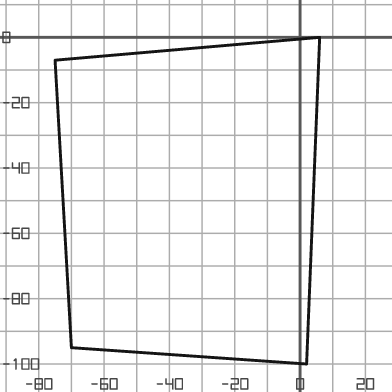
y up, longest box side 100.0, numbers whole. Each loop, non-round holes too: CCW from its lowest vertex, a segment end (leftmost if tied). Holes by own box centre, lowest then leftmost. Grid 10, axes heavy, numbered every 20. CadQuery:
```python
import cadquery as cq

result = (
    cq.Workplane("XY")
    .moveTo(2.0, -100.0)
    .lineTo(6.0, 0.0)
    .lineTo(-75.0, -7.0)
    .lineTo(-70.0, -95.0)
    .close()
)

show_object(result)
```